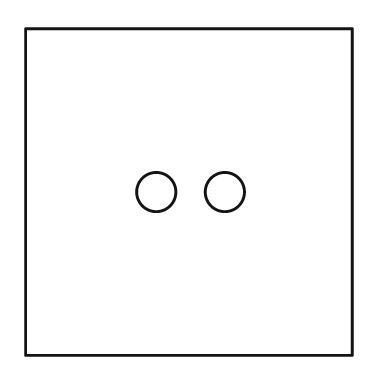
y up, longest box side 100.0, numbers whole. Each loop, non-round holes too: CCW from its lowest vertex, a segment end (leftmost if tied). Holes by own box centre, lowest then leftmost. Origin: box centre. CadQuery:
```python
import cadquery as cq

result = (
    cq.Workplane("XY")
    .moveTo(-50.0, -50.0)
    .lineTo(50.0, -50.0)
    .lineTo(50.0, 50.0)
    .lineTo(-50.0, 50.0)
    .close()
    .moveTo(-10.0, 0.0)
    .circle(6.0)
    .moveTo(11.0, 0.0)
    .circle(6.0)
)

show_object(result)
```